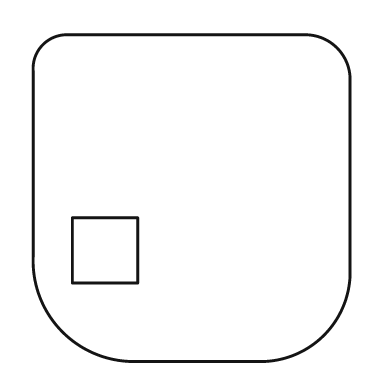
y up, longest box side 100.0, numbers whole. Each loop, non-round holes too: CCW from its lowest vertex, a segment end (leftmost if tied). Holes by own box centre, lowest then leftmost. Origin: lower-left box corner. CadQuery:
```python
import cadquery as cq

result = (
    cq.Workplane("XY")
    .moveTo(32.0, 0.0)
    .lineTo(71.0, 0.0)
    .threePointArc((89.0, 8.0), (97.0, 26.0))
    .lineTo(97.0, 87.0)
    .threePointArc((93.0, 96.0), (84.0, 100.0))
    .lineTo(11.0, 100.0)
    .threePointArc((3.0, 97.0), (0.0, 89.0))
    .lineTo(0.0, 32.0)
    .threePointArc((9.0, 9.0), (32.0, 0.0))
    .close()
    .moveTo(12.0, 24.0)
    .lineTo(32.0, 24.0)
    .lineTo(32.0, 44.0)
    .lineTo(12.0, 44.0)
    .close()
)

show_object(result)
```